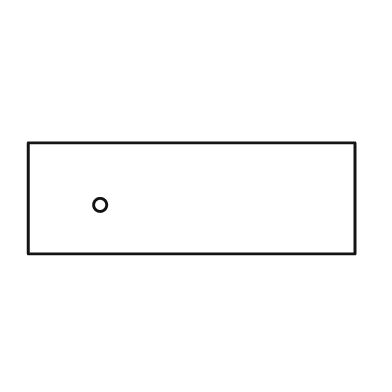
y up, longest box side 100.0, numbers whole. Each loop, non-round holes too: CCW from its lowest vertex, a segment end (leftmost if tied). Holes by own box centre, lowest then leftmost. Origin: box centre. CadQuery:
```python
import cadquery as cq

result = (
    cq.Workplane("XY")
    .moveTo(-50.0, -17.0)
    .lineTo(50.0, -17.0)
    .lineTo(50.0, 17.0)
    .lineTo(-50.0, 17.0)
    .close()
    .moveTo(-28.0, -2.0)
    .circle(2.0)
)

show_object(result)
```